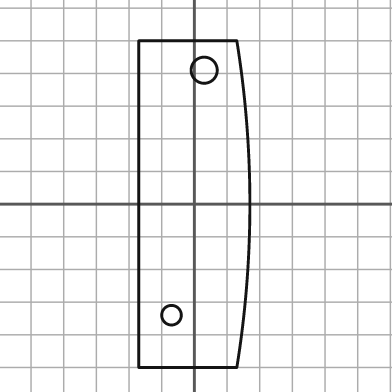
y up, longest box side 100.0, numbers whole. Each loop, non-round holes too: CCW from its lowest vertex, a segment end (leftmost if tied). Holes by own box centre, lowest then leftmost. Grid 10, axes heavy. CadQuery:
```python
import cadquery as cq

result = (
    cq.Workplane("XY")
    .moveTo(-17.0, -50.0)
    .lineTo(13.0, -50.0)
    .threePointArc((17.0, 0.0), (13.0, 50.0))
    .lineTo(-17.0, 50.0)
    .close()
    .moveTo(-7.0, -34.0)
    .circle(3.0)
    .moveTo(3.0, 41.0)
    .circle(4.0)
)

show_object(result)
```